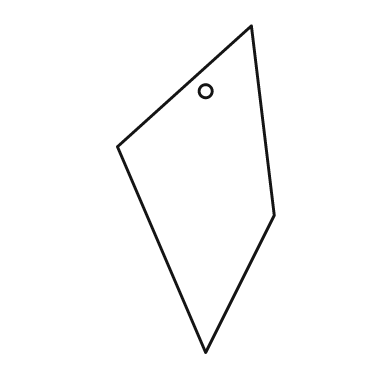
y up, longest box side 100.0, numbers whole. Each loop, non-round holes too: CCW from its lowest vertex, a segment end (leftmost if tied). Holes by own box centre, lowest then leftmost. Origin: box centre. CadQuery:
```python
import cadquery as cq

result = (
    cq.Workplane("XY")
    .moveTo(3.0, -50.0)
    .lineTo(24.0, -8.0)
    .lineTo(17.0, 50.0)
    .lineTo(-24.0, 13.0)
    .close()
    .moveTo(3.0, 30.0)
    .circle(2.0)
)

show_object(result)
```